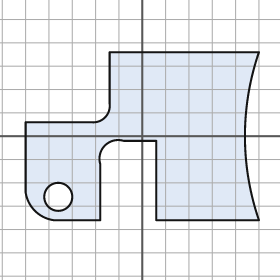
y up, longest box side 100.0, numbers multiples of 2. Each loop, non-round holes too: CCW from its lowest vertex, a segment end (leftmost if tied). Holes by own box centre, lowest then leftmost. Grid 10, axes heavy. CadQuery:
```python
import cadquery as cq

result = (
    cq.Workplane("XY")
    .moveTo(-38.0, -36.0)
    .lineTo(-18.0, -36.0)
    .lineTo(-18.0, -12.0)
    .threePointArc((-16.0, -4.0), (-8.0, -2.0))
    .lineTo(6.0, -2.0)
    .lineTo(6.0, -36.0)
    .lineTo(50.0, -36.0)
    .threePointArc((44.0, 0.0), (50.0, 36.0))
    .lineTo(-14.0, 36.0)
    .lineTo(-14.0, 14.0)
    .threePointArc((-16.0, 8.0), (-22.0, 6.0))
    .lineTo(-50.0, 6.0)
    .lineTo(-50.0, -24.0)
    .threePointArc((-46.0, -32.0), (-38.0, -36.0))
    .close()
    .moveTo(-36.0, -26.0)
    .circle(6.0)
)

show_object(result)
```